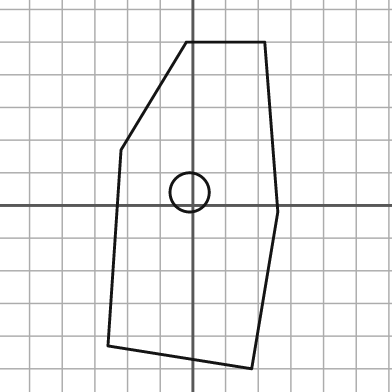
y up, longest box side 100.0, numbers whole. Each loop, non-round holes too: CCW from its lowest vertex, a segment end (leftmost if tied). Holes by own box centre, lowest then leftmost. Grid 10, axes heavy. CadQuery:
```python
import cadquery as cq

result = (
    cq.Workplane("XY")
    .moveTo(18.0, -50.0)
    .lineTo(26.0, -2.0)
    .lineTo(22.0, 50.0)
    .lineTo(-2.0, 50.0)
    .lineTo(-22.0, 17.0)
    .lineTo(-26.0, -43.0)
    .close()
    .moveTo(-1.0, 4.0)
    .circle(6.0)
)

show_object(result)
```